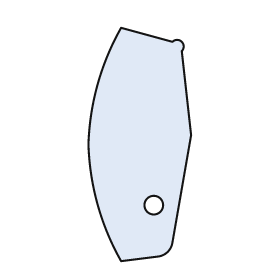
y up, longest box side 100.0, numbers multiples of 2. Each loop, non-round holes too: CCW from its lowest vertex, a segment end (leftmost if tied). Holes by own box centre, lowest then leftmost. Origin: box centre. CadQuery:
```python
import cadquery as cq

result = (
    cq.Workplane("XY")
    .moveTo(-8.0, -50.0)
    .lineTo(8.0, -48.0)
    .threePointArc((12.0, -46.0), (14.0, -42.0))
    .lineTo(22.0, 4.0)
    .lineTo(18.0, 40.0)
    .threePointArc((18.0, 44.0), (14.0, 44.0))
    .lineTo(-8.0, 50.0)
    .threePointArc((-18.0, 26.0), (-22.0, 0.0))
    .threePointArc((-18.0, -26.0), (-8.0, -50.0))
    .close()
    .moveTo(6.0, -26.0)
    .circle(4.0)
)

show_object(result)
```